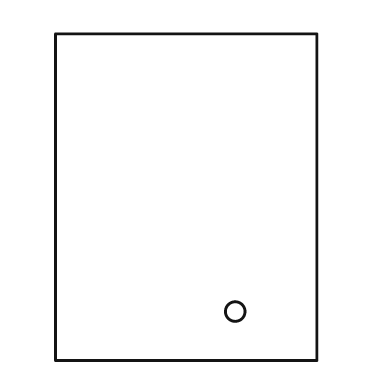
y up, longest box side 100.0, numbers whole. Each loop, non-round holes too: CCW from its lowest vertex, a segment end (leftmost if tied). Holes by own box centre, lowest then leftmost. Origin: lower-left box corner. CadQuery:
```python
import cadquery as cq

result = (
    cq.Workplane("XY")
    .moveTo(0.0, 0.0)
    .lineTo(80.0, 0.0)
    .lineTo(80.0, 100.0)
    .lineTo(0.0, 100.0)
    .close()
    .moveTo(55.0, 15.0)
    .circle(3.0)
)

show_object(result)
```